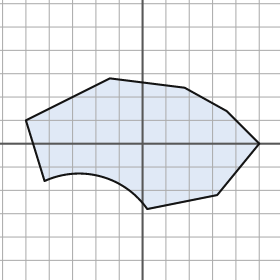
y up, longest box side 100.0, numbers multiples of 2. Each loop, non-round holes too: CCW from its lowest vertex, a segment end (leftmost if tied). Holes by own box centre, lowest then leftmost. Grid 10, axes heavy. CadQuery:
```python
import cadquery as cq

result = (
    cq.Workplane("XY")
    .moveTo(2.0, -28.0)
    .lineTo(32.0, -22.0)
    .lineTo(50.0, 0.0)
    .lineTo(36.0, 14.0)
    .lineTo(18.0, 24.0)
    .lineTo(-14.0, 28.0)
    .lineTo(-50.0, 10.0)
    .lineTo(-42.0, -16.0)
    .threePointArc((-18.0, -14.0), (2.0, -28.0))
    .close()
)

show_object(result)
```